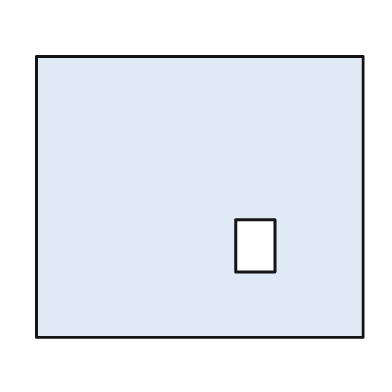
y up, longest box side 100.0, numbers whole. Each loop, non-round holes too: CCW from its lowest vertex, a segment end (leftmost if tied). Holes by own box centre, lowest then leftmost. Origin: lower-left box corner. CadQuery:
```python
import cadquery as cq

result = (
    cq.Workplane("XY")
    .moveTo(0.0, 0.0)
    .lineTo(100.0, 0.0)
    .lineTo(100.0, 86.0)
    .lineTo(0.0, 86.0)
    .close()
    .moveTo(61.0, 20.0)
    .lineTo(73.0, 20.0)
    .lineTo(73.0, 36.0)
    .lineTo(61.0, 36.0)
    .close()
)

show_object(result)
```